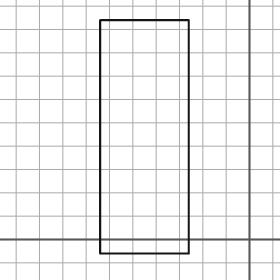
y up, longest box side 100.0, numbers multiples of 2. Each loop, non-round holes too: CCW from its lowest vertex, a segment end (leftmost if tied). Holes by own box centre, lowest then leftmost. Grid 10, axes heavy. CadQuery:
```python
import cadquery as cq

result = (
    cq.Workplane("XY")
    .moveTo(-64.0, -6.0)
    .lineTo(-26.0, -6.0)
    .lineTo(-26.0, 94.0)
    .lineTo(-64.0, 94.0)
    .close()
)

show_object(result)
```